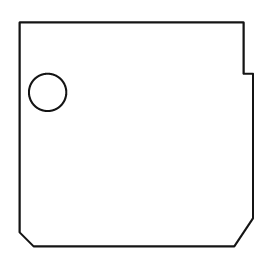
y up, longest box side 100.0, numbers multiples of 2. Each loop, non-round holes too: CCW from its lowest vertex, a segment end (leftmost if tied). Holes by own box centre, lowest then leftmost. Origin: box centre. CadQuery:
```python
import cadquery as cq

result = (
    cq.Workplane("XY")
    .moveTo(-44.0, -48.0)
    .lineTo(42.0, -48.0)
    .lineTo(50.0, -36.0)
    .lineTo(50.0, 26.0)
    .lineTo(46.0, 26.0)
    .lineTo(46.0, 48.0)
    .lineTo(-50.0, 48.0)
    .lineTo(-50.0, -42.0)
    .close()
    .moveTo(-38.0, 18.0)
    .circle(8.0)
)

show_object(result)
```